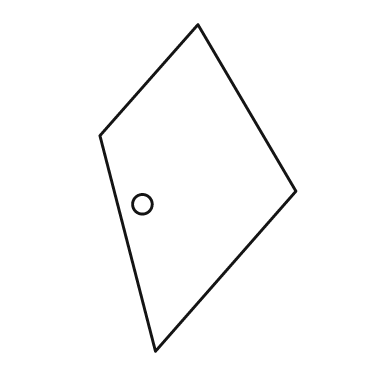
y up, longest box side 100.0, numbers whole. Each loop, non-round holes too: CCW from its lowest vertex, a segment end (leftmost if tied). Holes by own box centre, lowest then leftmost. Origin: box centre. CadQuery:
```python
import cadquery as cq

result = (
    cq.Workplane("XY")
    .moveTo(-13.0, -50.0)
    .lineTo(30.0, -1.0)
    .lineTo(0.0, 50.0)
    .lineTo(-30.0, 16.0)
    .close()
    .moveTo(-17.0, -5.0)
    .circle(3.0)
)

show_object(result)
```